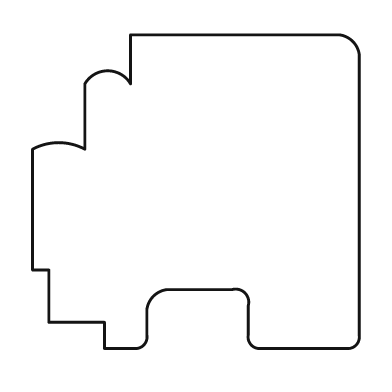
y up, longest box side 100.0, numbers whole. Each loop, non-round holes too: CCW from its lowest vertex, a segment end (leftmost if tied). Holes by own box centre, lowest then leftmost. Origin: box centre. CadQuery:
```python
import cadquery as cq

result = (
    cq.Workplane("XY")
    .moveTo(-28.0, -48.0)
    .lineTo(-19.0, -48.0)
    .threePointArc((-16.0, -47.0), (-15.0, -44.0))
    .lineTo(-15.0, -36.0)
    .threePointArc((-13.0, -32.0), (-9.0, -30.0))
    .lineTo(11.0, -30.0)
    .threePointArc((15.0, -31.0), (16.0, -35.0))
    .lineTo(16.0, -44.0)
    .threePointArc((17.0, -47.0), (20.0, -48.0))
    .lineTo(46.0, -48.0)
    .threePointArc((49.0, -47.0), (50.0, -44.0))
    .lineTo(50.0, 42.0)
    .threePointArc((48.0, 46.0), (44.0, 48.0))
    .lineTo(-20.0, 48.0)
    .lineTo(-20.0, 33.0)
    .threePointArc((-27.0, 37.0), (-34.0, 33.0))
    .lineTo(-34.0, 13.0)
    .threePointArc((-42.0, 15.0), (-50.0, 13.0))
    .lineTo(-50.0, -24.0)
    .lineTo(-45.0, -24.0)
    .lineTo(-45.0, -40.0)
    .lineTo(-28.0, -40.0)
    .close()
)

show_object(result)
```